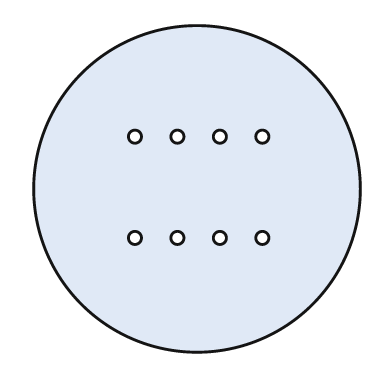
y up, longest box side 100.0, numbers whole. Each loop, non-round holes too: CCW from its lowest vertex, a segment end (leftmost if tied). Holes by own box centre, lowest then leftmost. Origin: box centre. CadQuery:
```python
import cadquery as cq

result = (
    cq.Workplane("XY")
    .moveTo(0.0, 0.0)
    .circle(50.0)
    .moveTo(-19.0, -15.0)
    .circle(2.0)
    .moveTo(-6.0, -15.0)
    .circle(2.0)
    .moveTo(7.0, -15.0)
    .circle(2.0)
    .moveTo(20.0, -15.0)
    .circle(2.0)
    .moveTo(-19.0, 16.0)
    .circle(2.0)
    .moveTo(-6.0, 16.0)
    .circle(2.0)
    .moveTo(7.0, 16.0)
    .circle(2.0)
    .moveTo(20.0, 16.0)
    .circle(2.0)
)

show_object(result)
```